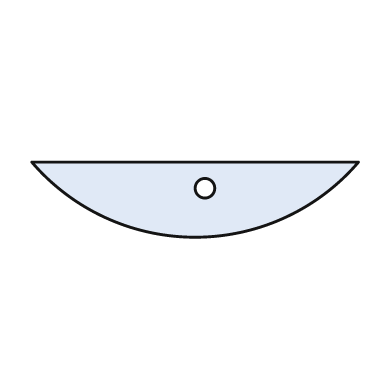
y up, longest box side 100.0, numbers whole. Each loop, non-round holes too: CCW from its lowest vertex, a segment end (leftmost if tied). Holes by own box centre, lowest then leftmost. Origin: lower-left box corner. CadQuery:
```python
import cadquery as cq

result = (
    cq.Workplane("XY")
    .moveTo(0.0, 23.0)
    .threePointArc((50.0, 0.0), (100.0, 23.0))
    .close()
    .moveTo(53.0, 15.0)
    .circle(3.0)
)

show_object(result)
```